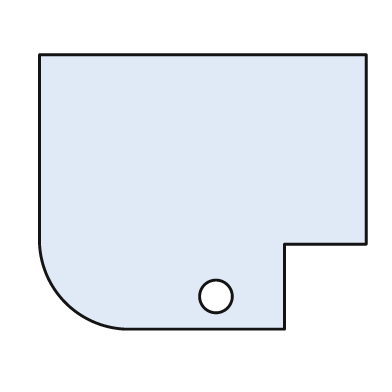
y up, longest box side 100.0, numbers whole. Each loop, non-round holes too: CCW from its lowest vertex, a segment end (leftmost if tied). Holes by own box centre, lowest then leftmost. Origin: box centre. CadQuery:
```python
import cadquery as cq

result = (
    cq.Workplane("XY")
    .moveTo(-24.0, -42.0)
    .lineTo(25.0, -42.0)
    .lineTo(25.0, -16.0)
    .lineTo(50.0, -16.0)
    .lineTo(50.0, 42.0)
    .lineTo(-50.0, 42.0)
    .lineTo(-50.0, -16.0)
    .threePointArc((-42.0, -34.0), (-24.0, -42.0))
    .close()
    .moveTo(4.0, -32.0)
    .circle(5.0)
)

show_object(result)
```